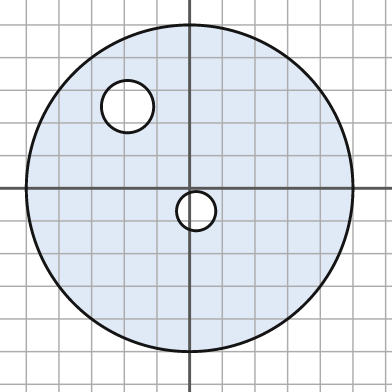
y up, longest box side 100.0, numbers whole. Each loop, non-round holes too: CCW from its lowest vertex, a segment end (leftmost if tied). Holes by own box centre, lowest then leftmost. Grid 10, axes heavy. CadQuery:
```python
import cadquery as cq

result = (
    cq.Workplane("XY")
    .moveTo(0.0, 0.0)
    .circle(50.0)
    .moveTo(2.0, -7.0)
    .circle(6.0)
    .moveTo(-19.0, 25.0)
    .circle(8.0)
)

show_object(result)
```